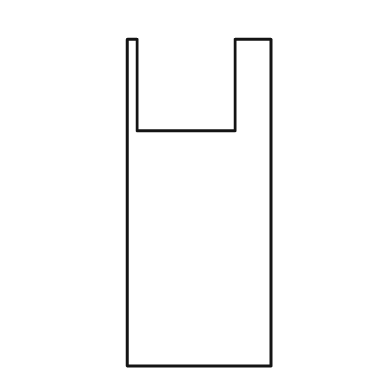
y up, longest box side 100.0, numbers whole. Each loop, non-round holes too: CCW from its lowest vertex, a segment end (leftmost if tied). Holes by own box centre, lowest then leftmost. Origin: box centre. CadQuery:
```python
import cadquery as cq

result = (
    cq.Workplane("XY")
    .moveTo(-22.0, -50.0)
    .lineTo(22.0, -50.0)
    .lineTo(22.0, 50.0)
    .lineTo(11.0, 50.0)
    .lineTo(11.0, 22.0)
    .lineTo(-19.0, 22.0)
    .lineTo(-19.0, 50.0)
    .lineTo(-22.0, 50.0)
    .close()
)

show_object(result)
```